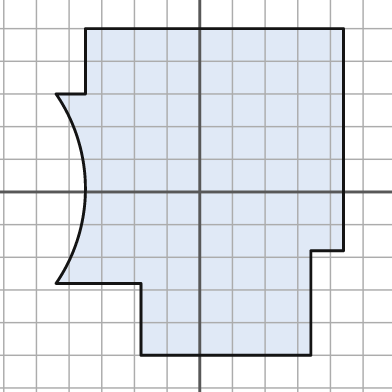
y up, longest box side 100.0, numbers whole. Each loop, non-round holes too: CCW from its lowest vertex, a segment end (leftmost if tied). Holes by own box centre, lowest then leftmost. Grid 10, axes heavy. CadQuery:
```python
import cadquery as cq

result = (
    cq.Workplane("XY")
    .moveTo(-18.0, -50.0)
    .lineTo(34.0, -50.0)
    .lineTo(34.0, -18.0)
    .lineTo(44.0, -18.0)
    .lineTo(44.0, 50.0)
    .lineTo(-35.0, 50.0)
    .lineTo(-35.0, 30.0)
    .lineTo(-44.0, 30.0)
    .threePointArc((-35.0, 1.0), (-44.0, -28.0))
    .lineTo(-18.0, -28.0)
    .close()
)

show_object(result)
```